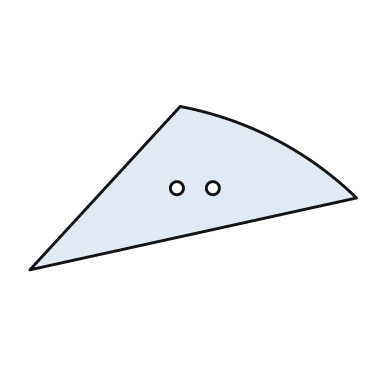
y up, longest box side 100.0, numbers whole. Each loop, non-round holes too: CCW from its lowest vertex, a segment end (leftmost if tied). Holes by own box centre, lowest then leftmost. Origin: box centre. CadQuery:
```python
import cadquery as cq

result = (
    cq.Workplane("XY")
    .moveTo(-50.0, -25.0)
    .lineTo(50.0, -3.0)
    .threePointArc((25.0, 15.0), (-4.0, 25.0))
    .close()
    .moveTo(-5.0, 0.0)
    .circle(2.0)
    .moveTo(6.0, 0.0)
    .circle(2.0)
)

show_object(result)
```